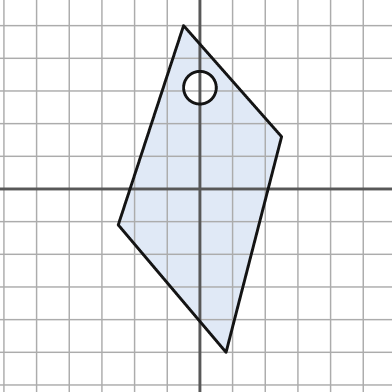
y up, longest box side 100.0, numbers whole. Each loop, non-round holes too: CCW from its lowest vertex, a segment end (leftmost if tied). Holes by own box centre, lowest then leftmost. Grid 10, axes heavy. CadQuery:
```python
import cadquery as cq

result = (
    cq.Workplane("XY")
    .moveTo(8.0, -50.0)
    .lineTo(25.0, 16.0)
    .lineTo(-5.0, 50.0)
    .lineTo(-25.0, -11.0)
    .close()
    .moveTo(0.0, 31.0)
    .circle(5.0)
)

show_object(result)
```